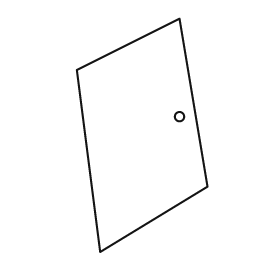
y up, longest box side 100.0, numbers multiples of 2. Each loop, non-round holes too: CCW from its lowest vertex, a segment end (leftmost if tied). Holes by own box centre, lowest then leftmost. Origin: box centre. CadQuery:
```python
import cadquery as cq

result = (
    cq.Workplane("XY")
    .moveTo(-18.0, -50.0)
    .lineTo(28.0, -22.0)
    .lineTo(16.0, 50.0)
    .lineTo(-28.0, 28.0)
    .close()
    .moveTo(16.0, 8.0)
    .circle(2.0)
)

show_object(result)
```